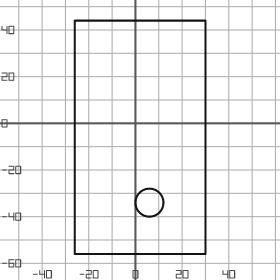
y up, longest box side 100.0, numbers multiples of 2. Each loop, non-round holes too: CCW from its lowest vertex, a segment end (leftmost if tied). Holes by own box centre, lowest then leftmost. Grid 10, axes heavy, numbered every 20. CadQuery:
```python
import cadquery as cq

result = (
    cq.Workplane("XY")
    .moveTo(-26.0, -56.0)
    .lineTo(30.0, -56.0)
    .lineTo(30.0, 44.0)
    .lineTo(-26.0, 44.0)
    .close()
    .moveTo(6.0, -34.0)
    .circle(6.0)
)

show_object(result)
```